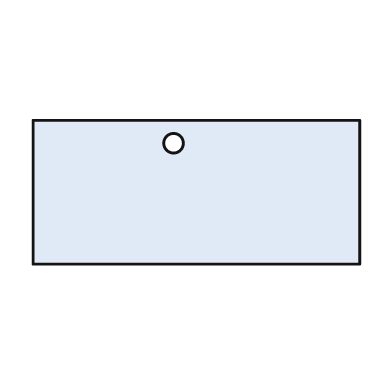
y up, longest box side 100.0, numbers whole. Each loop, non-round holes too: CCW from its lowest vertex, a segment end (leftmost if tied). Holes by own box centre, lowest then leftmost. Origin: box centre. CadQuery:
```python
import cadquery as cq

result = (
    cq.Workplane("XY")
    .moveTo(-50.0, -22.0)
    .lineTo(50.0, -22.0)
    .lineTo(50.0, 22.0)
    .lineTo(-50.0, 22.0)
    .close()
    .moveTo(-7.0, 15.0)
    .circle(3.0)
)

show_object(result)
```